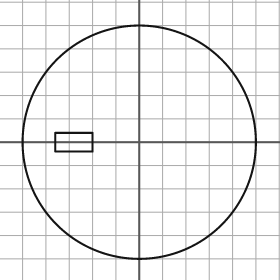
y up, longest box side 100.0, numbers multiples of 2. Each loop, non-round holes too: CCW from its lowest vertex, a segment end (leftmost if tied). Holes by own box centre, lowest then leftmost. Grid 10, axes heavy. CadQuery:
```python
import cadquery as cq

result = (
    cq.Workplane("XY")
    .moveTo(0.0, 0.0)
    .circle(50.0)
    .moveTo(-36.0, -4.0)
    .lineTo(-20.0, -4.0)
    .lineTo(-20.0, 4.0)
    .lineTo(-36.0, 4.0)
    .close()
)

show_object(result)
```